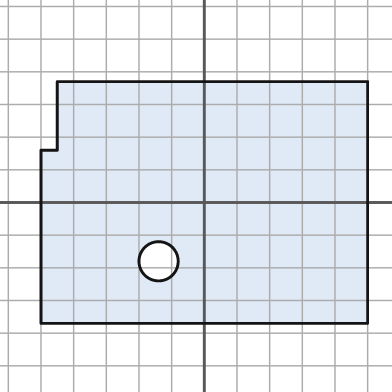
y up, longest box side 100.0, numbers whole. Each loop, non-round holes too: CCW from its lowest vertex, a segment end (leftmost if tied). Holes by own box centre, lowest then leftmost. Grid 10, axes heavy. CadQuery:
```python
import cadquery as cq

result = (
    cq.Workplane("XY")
    .moveTo(-50.0, -37.0)
    .lineTo(50.0, -37.0)
    .lineTo(50.0, 37.0)
    .lineTo(-45.0, 37.0)
    .lineTo(-45.0, 16.0)
    .lineTo(-50.0, 16.0)
    .close()
    .moveTo(-14.0, -18.0)
    .circle(6.0)
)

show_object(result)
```